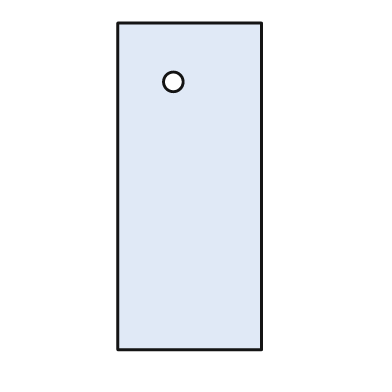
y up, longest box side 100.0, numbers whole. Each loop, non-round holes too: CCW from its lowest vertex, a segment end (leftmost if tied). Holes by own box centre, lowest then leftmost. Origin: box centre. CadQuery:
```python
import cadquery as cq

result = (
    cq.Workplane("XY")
    .moveTo(-22.0, -50.0)
    .lineTo(22.0, -50.0)
    .lineTo(22.0, 50.0)
    .lineTo(-22.0, 50.0)
    .close()
    .moveTo(-5.0, 32.0)
    .circle(3.0)
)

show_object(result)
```